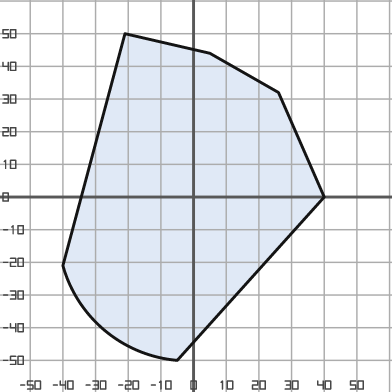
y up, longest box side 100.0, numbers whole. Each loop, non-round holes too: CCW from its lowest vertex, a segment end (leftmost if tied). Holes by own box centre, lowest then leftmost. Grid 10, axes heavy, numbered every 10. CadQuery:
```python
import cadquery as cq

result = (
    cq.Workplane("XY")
    .moveTo(-5.0, -50.0)
    .lineTo(40.0, 0.0)
    .lineTo(26.0, 32.0)
    .lineTo(5.0, 44.0)
    .lineTo(-21.0, 50.0)
    .lineTo(-40.0, -21.0)
    .threePointArc((-27.0, -41.0), (-5.0, -50.0))
    .close()
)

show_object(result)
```